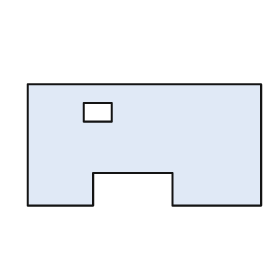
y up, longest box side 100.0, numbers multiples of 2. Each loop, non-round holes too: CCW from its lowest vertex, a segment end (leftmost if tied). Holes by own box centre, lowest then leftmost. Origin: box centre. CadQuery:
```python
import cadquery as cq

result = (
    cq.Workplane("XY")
    .moveTo(-50.0, -26.0)
    .lineTo(-22.0, -26.0)
    .lineTo(-22.0, -12.0)
    .lineTo(12.0, -12.0)
    .lineTo(12.0, -26.0)
    .lineTo(50.0, -26.0)
    .lineTo(50.0, 26.0)
    .lineTo(-50.0, 26.0)
    .close()
    .moveTo(-26.0, 10.0)
    .lineTo(-14.0, 10.0)
    .lineTo(-14.0, 18.0)
    .lineTo(-26.0, 18.0)
    .close()
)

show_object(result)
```